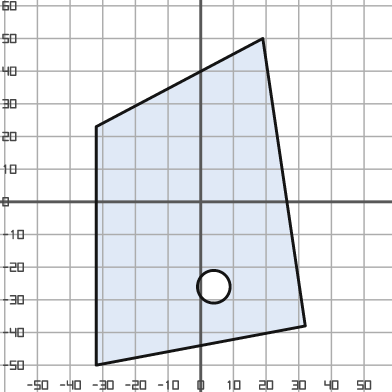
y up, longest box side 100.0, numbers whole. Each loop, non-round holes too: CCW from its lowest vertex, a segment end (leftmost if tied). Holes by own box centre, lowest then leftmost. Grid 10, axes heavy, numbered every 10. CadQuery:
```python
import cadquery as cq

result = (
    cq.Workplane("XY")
    .moveTo(-32.0, -50.0)
    .lineTo(32.0, -38.0)
    .lineTo(19.0, 50.0)
    .lineTo(-32.0, 23.0)
    .close()
    .moveTo(4.0, -26.0)
    .circle(5.0)
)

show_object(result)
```